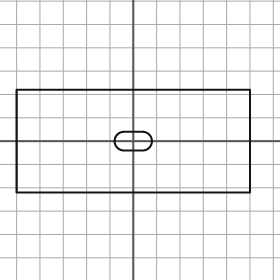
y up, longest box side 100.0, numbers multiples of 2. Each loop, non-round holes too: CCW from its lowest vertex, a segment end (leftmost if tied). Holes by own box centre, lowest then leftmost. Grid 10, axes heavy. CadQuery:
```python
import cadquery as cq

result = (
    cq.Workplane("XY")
    .moveTo(-50.0, -22.0)
    .lineTo(50.0, -22.0)
    .lineTo(50.0, 22.0)
    .lineTo(-50.0, 22.0)
    .close()
    .moveTo(-4.0, -4.0)
    .lineTo(4.0, -4.0)
    .threePointArc((8.0, 0.0), (4.0, 4.0))
    .lineTo(-4.0, 4.0)
    .threePointArc((-8.0, 0.0), (-4.0, -4.0))
    .close()
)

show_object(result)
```